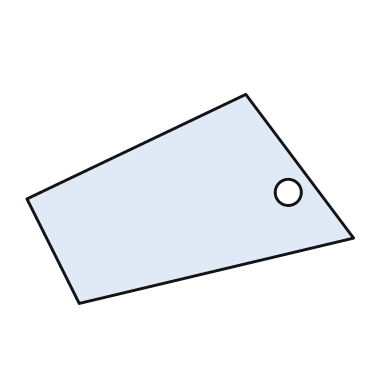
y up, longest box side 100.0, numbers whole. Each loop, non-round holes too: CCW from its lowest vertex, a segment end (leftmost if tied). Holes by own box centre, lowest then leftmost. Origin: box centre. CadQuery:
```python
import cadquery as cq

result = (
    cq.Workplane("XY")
    .moveTo(-34.0, -32.0)
    .lineTo(50.0, -12.0)
    .lineTo(17.0, 32.0)
    .lineTo(-50.0, 0.0)
    .close()
    .moveTo(30.0, 2.0)
    .circle(4.0)
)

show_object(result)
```